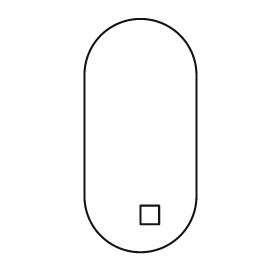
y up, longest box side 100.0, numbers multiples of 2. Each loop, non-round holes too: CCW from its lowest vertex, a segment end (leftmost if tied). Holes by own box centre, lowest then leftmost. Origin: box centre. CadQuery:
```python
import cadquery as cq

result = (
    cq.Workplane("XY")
    .moveTo(-24.0, -26.0)
    .threePointArc((0.0, -50.0), (24.0, -26.0))
    .lineTo(24.0, 26.0)
    .threePointArc((0.0, 50.0), (-24.0, 26.0))
    .close()
    .moveTo(0.0, -38.0)
    .lineTo(8.0, -38.0)
    .lineTo(8.0, -30.0)
    .lineTo(0.0, -30.0)
    .close()
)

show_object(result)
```